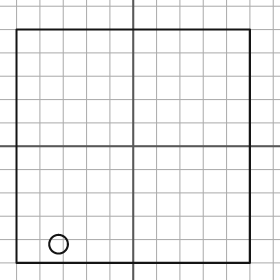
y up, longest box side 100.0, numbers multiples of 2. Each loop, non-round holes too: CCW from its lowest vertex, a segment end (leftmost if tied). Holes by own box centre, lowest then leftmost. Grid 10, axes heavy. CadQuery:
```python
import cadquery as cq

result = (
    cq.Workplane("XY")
    .moveTo(-50.0, -50.0)
    .lineTo(50.0, -50.0)
    .lineTo(50.0, 50.0)
    .lineTo(-50.0, 50.0)
    .close()
    .moveTo(-32.0, -42.0)
    .circle(4.0)
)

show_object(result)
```